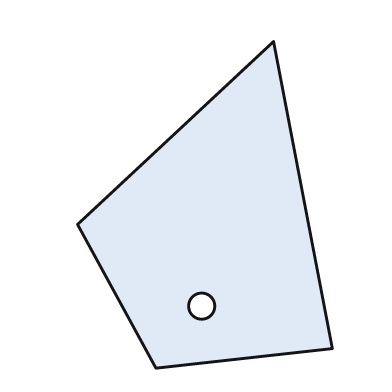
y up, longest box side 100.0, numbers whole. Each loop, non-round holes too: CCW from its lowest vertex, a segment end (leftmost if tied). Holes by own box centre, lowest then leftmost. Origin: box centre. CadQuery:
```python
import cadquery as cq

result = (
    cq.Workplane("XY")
    .moveTo(-15.0, -50.0)
    .lineTo(39.0, -44.0)
    .lineTo(21.0, 50.0)
    .lineTo(-39.0, -6.0)
    .close()
    .moveTo(-1.0, -31.0)
    .circle(4.0)
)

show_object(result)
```